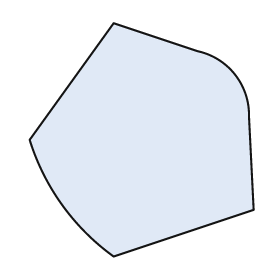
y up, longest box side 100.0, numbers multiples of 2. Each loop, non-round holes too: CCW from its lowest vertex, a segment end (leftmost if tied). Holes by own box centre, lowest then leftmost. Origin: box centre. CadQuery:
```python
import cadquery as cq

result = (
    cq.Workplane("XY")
    .moveTo(-12.0, -50.0)
    .lineTo(48.0, -30.0)
    .lineTo(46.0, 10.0)
    .threePointArc((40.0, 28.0), (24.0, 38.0))
    .lineTo(-12.0, 50.0)
    .lineTo(-48.0, 0.0)
    .threePointArc((-34.0, -28.0), (-12.0, -50.0))
    .close()
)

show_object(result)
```